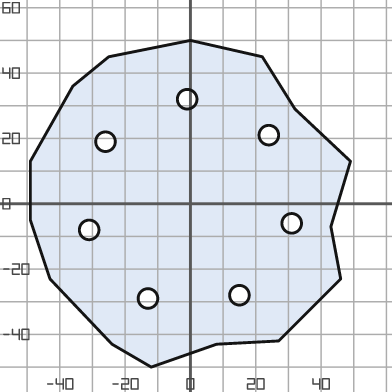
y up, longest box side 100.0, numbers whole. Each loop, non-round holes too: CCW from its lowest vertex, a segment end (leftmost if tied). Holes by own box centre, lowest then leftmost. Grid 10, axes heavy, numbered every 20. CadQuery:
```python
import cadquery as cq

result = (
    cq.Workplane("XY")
    .moveTo(-12.0, -50.0)
    .lineTo(8.0, -43.0)
    .lineTo(27.0, -42.0)
    .lineTo(46.0, -23.0)
    .lineTo(43.0, -7.0)
    .lineTo(49.0, 13.0)
    .lineTo(32.0, 29.0)
    .lineTo(22.0, 45.0)
    .lineTo(0.0, 50.0)
    .lineTo(-25.0, 45.0)
    .lineTo(-36.0, 36.0)
    .lineTo(-49.0, 13.0)
    .lineTo(-49.0, -5.0)
    .lineTo(-43.0, -23.0)
    .lineTo(-24.0, -43.0)
    .close()
    .moveTo(-13.0, -29.0)
    .circle(3.0)
    .moveTo(15.0, -28.0)
    .circle(3.0)
    .moveTo(-31.0, -8.0)
    .circle(3.0)
    .moveTo(31.0, -6.0)
    .circle(3.0)
    .moveTo(-26.0, 19.0)
    .circle(3.0)
    .moveTo(24.0, 21.0)
    .circle(3.0)
    .moveTo(-1.0, 32.0)
    .circle(3.0)
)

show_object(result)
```